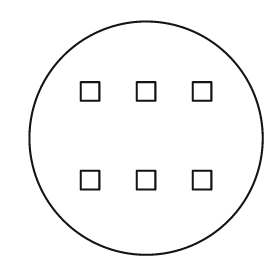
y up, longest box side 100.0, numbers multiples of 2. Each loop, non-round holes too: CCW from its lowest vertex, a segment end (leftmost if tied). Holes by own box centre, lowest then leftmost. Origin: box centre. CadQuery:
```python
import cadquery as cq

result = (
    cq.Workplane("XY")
    .moveTo(0.0, 0.0)
    .circle(50.0)
    .moveTo(-28.0, -22.0)
    .lineTo(-20.0, -22.0)
    .lineTo(-20.0, -14.0)
    .lineTo(-28.0, -14.0)
    .close()
    .moveTo(-4.0, -22.0)
    .lineTo(4.0, -22.0)
    .lineTo(4.0, -14.0)
    .lineTo(-4.0, -14.0)
    .close()
    .moveTo(20.0, -22.0)
    .lineTo(28.0, -22.0)
    .lineTo(28.0, -14.0)
    .lineTo(20.0, -14.0)
    .close()
    .moveTo(-28.0, 16.0)
    .lineTo(-20.0, 16.0)
    .lineTo(-20.0, 24.0)
    .lineTo(-28.0, 24.0)
    .close()
    .moveTo(-4.0, 16.0)
    .lineTo(4.0, 16.0)
    .lineTo(4.0, 24.0)
    .lineTo(-4.0, 24.0)
    .close()
    .moveTo(20.0, 16.0)
    .lineTo(28.0, 16.0)
    .lineTo(28.0, 24.0)
    .lineTo(20.0, 24.0)
    .close()
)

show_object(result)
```